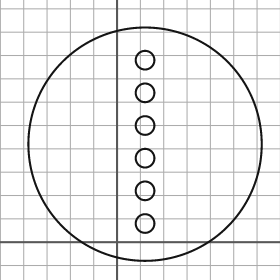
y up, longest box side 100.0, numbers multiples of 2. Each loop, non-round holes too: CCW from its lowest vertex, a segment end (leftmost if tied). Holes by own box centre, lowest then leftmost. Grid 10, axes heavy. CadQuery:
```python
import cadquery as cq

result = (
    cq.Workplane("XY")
    .moveTo(12.0, 42.0)
    .circle(50.0)
    .moveTo(12.0, 8.0)
    .circle(4.0)
    .moveTo(12.0, 22.0)
    .circle(4.0)
    .moveTo(12.0, 36.0)
    .circle(4.0)
    .moveTo(12.0, 50.0)
    .circle(4.0)
    .moveTo(12.0, 64.0)
    .circle(4.0)
    .moveTo(12.0, 78.0)
    .circle(4.0)
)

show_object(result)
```